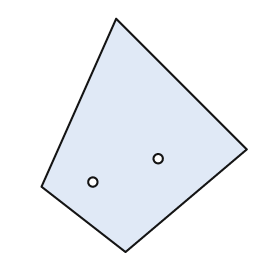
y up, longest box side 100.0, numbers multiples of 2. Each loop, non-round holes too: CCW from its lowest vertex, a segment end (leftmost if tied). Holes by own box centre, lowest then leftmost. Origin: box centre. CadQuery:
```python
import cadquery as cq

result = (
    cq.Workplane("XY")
    .moveTo(-8.0, -50.0)
    .lineTo(44.0, -6.0)
    .lineTo(-12.0, 50.0)
    .lineTo(-44.0, -22.0)
    .close()
    .moveTo(-22.0, -20.0)
    .circle(2.0)
    .moveTo(6.0, -10.0)
    .circle(2.0)
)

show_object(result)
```